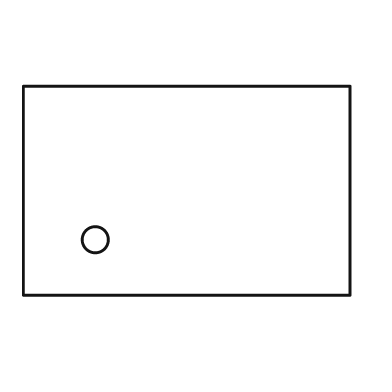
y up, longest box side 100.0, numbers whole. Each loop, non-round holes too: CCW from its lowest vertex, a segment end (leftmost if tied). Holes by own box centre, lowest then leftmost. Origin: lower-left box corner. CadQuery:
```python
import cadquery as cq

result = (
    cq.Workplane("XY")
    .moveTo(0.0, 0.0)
    .lineTo(100.0, 0.0)
    .lineTo(100.0, 64.0)
    .lineTo(0.0, 64.0)
    .close()
    .moveTo(22.0, 17.0)
    .circle(4.0)
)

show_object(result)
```